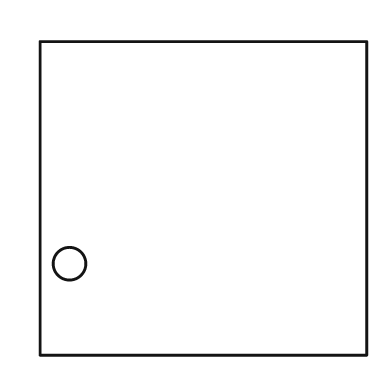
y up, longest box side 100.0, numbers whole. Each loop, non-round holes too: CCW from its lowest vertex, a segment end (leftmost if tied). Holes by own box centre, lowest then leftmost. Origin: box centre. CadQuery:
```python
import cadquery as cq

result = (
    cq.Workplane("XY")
    .moveTo(-50.0, -48.0)
    .lineTo(50.0, -48.0)
    .lineTo(50.0, 48.0)
    .lineTo(-50.0, 48.0)
    .close()
    .moveTo(-41.0, -20.0)
    .circle(5.0)
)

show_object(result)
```